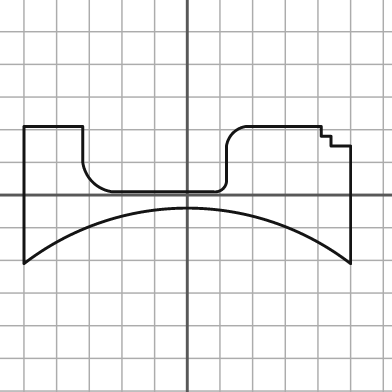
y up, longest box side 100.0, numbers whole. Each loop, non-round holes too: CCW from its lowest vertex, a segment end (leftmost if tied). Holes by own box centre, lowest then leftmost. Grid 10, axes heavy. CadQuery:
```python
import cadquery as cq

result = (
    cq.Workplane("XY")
    .moveTo(-50.0, -21.0)
    .threePointArc((0.0, -4.0), (50.0, -21.0))
    .lineTo(50.0, 15.0)
    .lineTo(44.0, 15.0)
    .lineTo(44.0, 18.0)
    .lineTo(41.0, 18.0)
    .lineTo(41.0, 21.0)
    .lineTo(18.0, 21.0)
    .threePointArc((14.0, 19.0), (12.0, 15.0))
    .lineTo(12.0, 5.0)
    .threePointArc((11.0, 2.0), (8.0, 1.0))
    .lineTo(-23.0, 1.0)
    .threePointArc((-29.0, 4.0), (-32.0, 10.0))
    .lineTo(-32.0, 21.0)
    .lineTo(-50.0, 21.0)
    .close()
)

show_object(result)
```